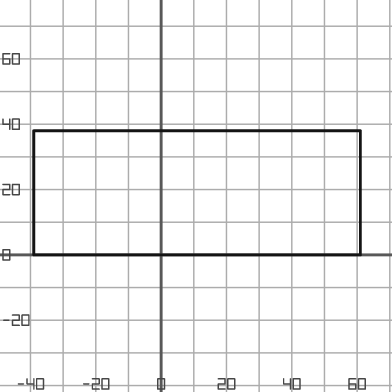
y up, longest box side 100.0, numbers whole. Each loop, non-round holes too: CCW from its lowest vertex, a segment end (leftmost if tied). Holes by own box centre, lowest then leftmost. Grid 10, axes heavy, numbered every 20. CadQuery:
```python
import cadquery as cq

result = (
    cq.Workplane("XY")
    .moveTo(-39.0, 0.0)
    .lineTo(61.0, 0.0)
    .lineTo(61.0, 38.0)
    .lineTo(-39.0, 38.0)
    .close()
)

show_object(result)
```